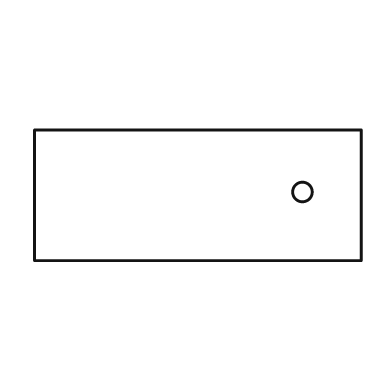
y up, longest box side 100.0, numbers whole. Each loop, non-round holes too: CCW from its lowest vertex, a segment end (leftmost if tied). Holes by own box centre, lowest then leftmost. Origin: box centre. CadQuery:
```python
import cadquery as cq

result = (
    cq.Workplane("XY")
    .moveTo(-50.0, -20.0)
    .lineTo(50.0, -20.0)
    .lineTo(50.0, 20.0)
    .lineTo(-50.0, 20.0)
    .close()
    .moveTo(32.0, 1.0)
    .circle(3.0)
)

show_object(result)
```